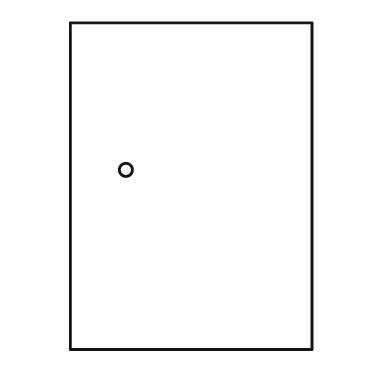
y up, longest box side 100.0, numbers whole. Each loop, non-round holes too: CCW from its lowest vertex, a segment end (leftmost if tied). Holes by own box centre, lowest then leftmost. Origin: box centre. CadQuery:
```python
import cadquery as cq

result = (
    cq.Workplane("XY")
    .moveTo(-37.0, -50.0)
    .lineTo(37.0, -50.0)
    .lineTo(37.0, 50.0)
    .lineTo(-37.0, 50.0)
    .close()
    .moveTo(-20.0, 5.0)
    .circle(2.0)
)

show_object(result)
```